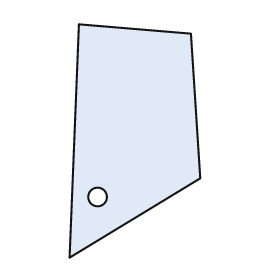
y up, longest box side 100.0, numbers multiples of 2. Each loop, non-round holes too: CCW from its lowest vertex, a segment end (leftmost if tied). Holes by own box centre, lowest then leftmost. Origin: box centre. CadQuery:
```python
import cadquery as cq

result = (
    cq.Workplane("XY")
    .moveTo(-28.0, -50.0)
    .lineTo(28.0, -16.0)
    .lineTo(24.0, 46.0)
    .lineTo(-24.0, 50.0)
    .close()
    .moveTo(-16.0, -24.0)
    .circle(4.0)
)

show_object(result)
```